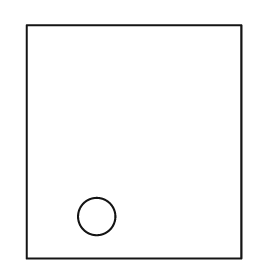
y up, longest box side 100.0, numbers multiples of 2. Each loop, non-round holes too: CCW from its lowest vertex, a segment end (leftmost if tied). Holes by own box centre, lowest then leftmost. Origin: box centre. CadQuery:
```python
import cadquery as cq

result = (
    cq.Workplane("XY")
    .moveTo(-46.0, -50.0)
    .lineTo(46.0, -50.0)
    .lineTo(46.0, 50.0)
    .lineTo(-46.0, 50.0)
    .close()
    .moveTo(-16.0, -32.0)
    .circle(8.0)
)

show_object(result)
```